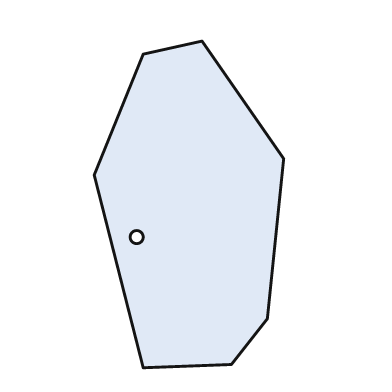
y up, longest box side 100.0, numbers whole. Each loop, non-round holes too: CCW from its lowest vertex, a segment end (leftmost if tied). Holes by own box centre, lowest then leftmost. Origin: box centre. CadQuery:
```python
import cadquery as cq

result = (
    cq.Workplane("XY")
    .moveTo(-14.0, -50.0)
    .lineTo(13.0, -49.0)
    .lineTo(24.0, -35.0)
    .lineTo(29.0, 14.0)
    .lineTo(4.0, 50.0)
    .lineTo(-14.0, 46.0)
    .lineTo(-29.0, 9.0)
    .close()
    .moveTo(-16.0, -10.0)
    .circle(2.0)
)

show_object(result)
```